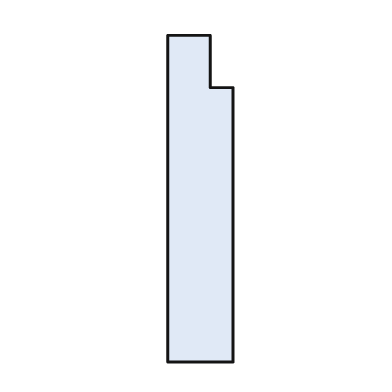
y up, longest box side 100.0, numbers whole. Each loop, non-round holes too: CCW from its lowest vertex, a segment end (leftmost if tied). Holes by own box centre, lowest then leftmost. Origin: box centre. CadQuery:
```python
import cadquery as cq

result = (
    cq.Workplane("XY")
    .moveTo(-10.0, -50.0)
    .lineTo(10.0, -50.0)
    .lineTo(10.0, 34.0)
    .lineTo(3.0, 34.0)
    .lineTo(3.0, 50.0)
    .lineTo(-10.0, 50.0)
    .close()
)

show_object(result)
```